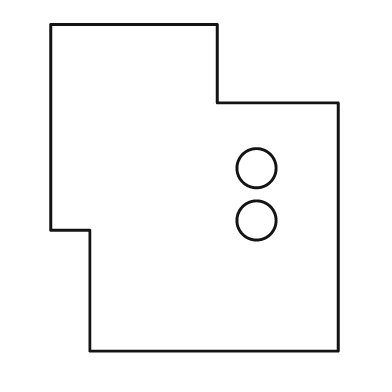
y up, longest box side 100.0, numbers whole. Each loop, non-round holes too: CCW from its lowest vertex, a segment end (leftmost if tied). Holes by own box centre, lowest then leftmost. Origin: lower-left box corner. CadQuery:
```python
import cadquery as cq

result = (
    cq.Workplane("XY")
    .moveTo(12.0, 0.0)
    .lineTo(88.0, 0.0)
    .lineTo(88.0, 76.0)
    .lineTo(51.0, 76.0)
    .lineTo(51.0, 100.0)
    .lineTo(0.0, 100.0)
    .lineTo(0.0, 37.0)
    .lineTo(12.0, 37.0)
    .close()
    .moveTo(63.0, 40.0)
    .circle(6.0)
    .moveTo(63.0, 56.0)
    .circle(6.0)
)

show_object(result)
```